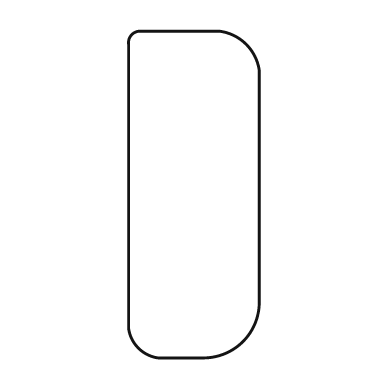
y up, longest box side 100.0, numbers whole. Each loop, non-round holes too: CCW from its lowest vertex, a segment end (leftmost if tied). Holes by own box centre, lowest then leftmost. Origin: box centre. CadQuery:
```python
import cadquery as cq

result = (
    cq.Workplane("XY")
    .moveTo(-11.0, -50.0)
    .lineTo(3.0, -50.0)
    .threePointArc((15.0, -45.0), (20.0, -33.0))
    .lineTo(20.0, 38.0)
    .threePointArc((16.0, 46.0), (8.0, 50.0))
    .lineTo(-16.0, 50.0)
    .threePointArc((-19.0, 49.0), (-20.0, 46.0))
    .lineTo(-20.0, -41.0)
    .threePointArc((-17.0, -47.0), (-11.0, -50.0))
    .close()
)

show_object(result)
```